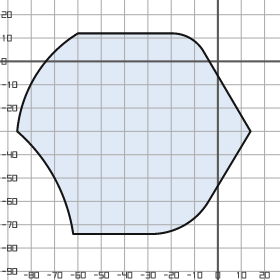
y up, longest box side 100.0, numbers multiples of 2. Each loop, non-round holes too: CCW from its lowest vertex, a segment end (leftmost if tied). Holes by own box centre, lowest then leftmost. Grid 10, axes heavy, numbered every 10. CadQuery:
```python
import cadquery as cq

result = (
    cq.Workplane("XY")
    .moveTo(-62.0, -74.0)
    .lineTo(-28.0, -74.0)
    .threePointArc((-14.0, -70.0), (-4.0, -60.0))
    .lineTo(14.0, -30.0)
    .lineTo(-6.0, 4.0)
    .threePointArc((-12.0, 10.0), (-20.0, 12.0))
    .lineTo(-60.0, 12.0)
    .threePointArc((-78.0, -6.0), (-86.0, -30.0))
    .threePointArc((-70.0, -50.0), (-62.0, -74.0))
    .close()
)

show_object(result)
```